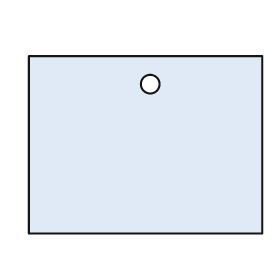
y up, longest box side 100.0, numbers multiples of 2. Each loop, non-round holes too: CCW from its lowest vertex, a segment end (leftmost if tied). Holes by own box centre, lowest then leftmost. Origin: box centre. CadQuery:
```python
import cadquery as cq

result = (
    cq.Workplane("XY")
    .moveTo(-50.0, -38.0)
    .lineTo(50.0, -38.0)
    .lineTo(50.0, 38.0)
    .lineTo(-50.0, 38.0)
    .close()
    .moveTo(2.0, 26.0)
    .circle(4.0)
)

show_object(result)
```